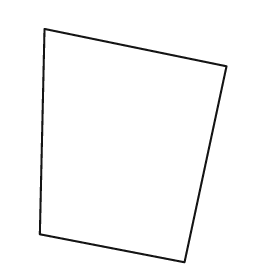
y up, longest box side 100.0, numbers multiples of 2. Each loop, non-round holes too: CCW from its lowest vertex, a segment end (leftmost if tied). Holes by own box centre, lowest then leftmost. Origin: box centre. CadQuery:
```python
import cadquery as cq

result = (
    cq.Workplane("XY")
    .moveTo(22.0, -50.0)
    .lineTo(40.0, 34.0)
    .lineTo(-38.0, 50.0)
    .lineTo(-40.0, -38.0)
    .close()
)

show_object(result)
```